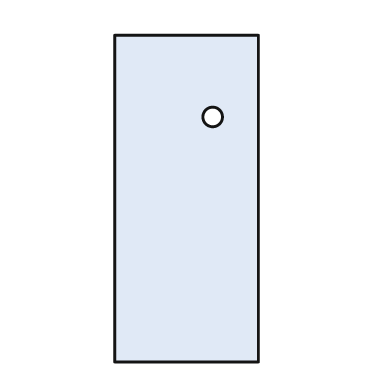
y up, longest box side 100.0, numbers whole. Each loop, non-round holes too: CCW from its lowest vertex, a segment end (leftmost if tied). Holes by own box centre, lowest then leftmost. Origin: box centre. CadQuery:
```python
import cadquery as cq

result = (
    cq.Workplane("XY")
    .moveTo(-22.0, -50.0)
    .lineTo(22.0, -50.0)
    .lineTo(22.0, 50.0)
    .lineTo(-22.0, 50.0)
    .close()
    .moveTo(8.0, 25.0)
    .circle(3.0)
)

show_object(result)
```